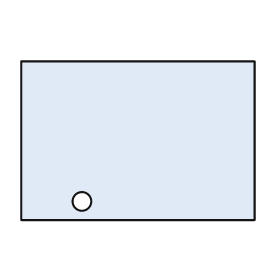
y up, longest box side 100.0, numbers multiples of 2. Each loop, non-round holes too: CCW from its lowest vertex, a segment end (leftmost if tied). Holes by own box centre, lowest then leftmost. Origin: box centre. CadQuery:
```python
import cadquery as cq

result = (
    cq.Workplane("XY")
    .moveTo(-50.0, -34.0)
    .lineTo(50.0, -34.0)
    .lineTo(50.0, 34.0)
    .lineTo(-50.0, 34.0)
    .close()
    .moveTo(-24.0, -26.0)
    .circle(4.0)
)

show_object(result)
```